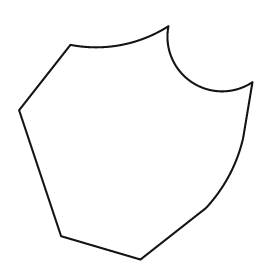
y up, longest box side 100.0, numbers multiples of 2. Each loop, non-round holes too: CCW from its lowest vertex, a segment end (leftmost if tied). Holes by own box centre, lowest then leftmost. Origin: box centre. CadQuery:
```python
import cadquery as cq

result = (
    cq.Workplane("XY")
    .moveTo(2.0, -50.0)
    .lineTo(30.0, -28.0)
    .threePointArc((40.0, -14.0), (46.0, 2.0))
    .lineTo(50.0, 26.0)
    .threePointArc((24.0, 26.0), (14.0, 50.0))
    .threePointArc((-6.0, 42.0), (-28.0, 42.0))
    .lineTo(-50.0, 14.0)
    .lineTo(-32.0, -40.0)
    .close()
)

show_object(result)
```